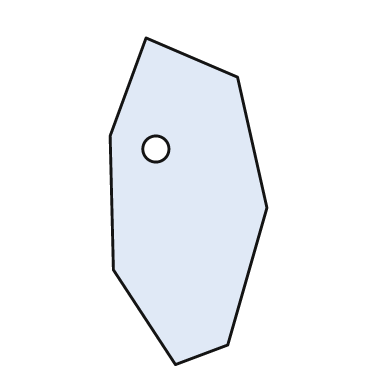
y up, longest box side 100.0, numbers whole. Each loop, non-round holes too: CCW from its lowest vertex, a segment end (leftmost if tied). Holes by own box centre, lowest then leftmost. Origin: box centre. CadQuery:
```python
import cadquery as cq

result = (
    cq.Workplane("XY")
    .moveTo(-4.0, -50.0)
    .lineTo(12.0, -44.0)
    .lineTo(24.0, -2.0)
    .lineTo(15.0, 38.0)
    .lineTo(-13.0, 50.0)
    .lineTo(-24.0, 20.0)
    .lineTo(-23.0, -21.0)
    .close()
    .moveTo(-10.0, 16.0)
    .circle(4.0)
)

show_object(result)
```